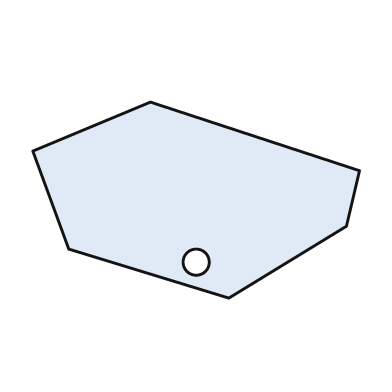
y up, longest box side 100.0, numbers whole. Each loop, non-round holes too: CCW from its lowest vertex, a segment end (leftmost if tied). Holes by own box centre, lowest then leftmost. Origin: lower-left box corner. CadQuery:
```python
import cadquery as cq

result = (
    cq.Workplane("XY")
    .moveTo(60.0, 0.0)
    .lineTo(96.0, 22.0)
    .lineTo(100.0, 39.0)
    .lineTo(36.0, 60.0)
    .lineTo(0.0, 45.0)
    .lineTo(11.0, 15.0)
    .close()
    .moveTo(50.0, 11.0)
    .circle(4.0)
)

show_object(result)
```